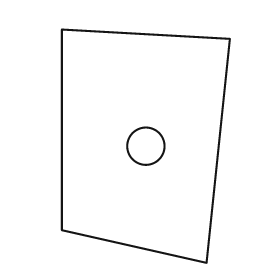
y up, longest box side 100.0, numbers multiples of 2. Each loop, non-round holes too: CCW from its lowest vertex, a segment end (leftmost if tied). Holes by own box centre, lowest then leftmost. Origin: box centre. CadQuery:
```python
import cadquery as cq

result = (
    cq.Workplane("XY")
    .moveTo(26.0, -50.0)
    .lineTo(36.0, 46.0)
    .lineTo(-36.0, 50.0)
    .lineTo(-36.0, -36.0)
    .close()
    .moveTo(0.0, 0.0)
    .circle(8.0)
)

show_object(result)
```